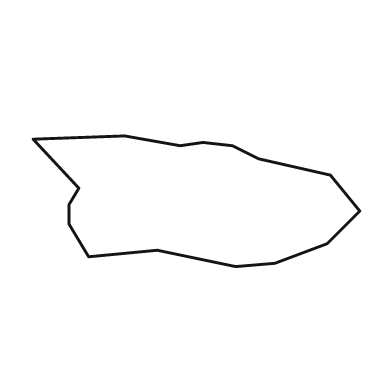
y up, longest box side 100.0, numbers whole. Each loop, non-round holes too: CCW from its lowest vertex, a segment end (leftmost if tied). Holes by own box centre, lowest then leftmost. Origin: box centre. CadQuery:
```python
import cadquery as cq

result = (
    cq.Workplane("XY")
    .moveTo(12.0, -20.0)
    .lineTo(24.0, -19.0)
    .lineTo(40.0, -13.0)
    .lineTo(50.0, -3.0)
    .lineTo(41.0, 8.0)
    .lineTo(19.0, 13.0)
    .lineTo(11.0, 17.0)
    .lineTo(2.0, 18.0)
    .lineTo(-5.0, 17.0)
    .lineTo(-22.0, 20.0)
    .lineTo(-50.0, 19.0)
    .lineTo(-36.0, 4.0)
    .lineTo(-39.0, -1.0)
    .lineTo(-39.0, -7.0)
    .lineTo(-33.0, -17.0)
    .lineTo(-12.0, -15.0)
    .close()
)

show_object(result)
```